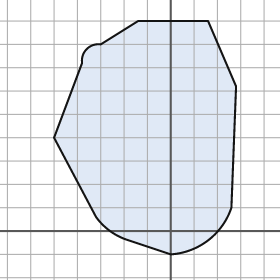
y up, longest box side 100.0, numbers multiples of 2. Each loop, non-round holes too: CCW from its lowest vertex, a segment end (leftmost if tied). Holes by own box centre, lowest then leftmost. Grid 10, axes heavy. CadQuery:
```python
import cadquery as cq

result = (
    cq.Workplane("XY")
    .moveTo(0.0, -10.0)
    .threePointArc((16.0, -4.0), (26.0, 10.0))
    .lineTo(28.0, 62.0)
    .lineTo(16.0, 90.0)
    .lineTo(-14.0, 90.0)
    .lineTo(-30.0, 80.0)
    .threePointArc((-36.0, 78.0), (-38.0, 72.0))
    .lineTo(-50.0, 40.0)
    .lineTo(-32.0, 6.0)
    .threePointArc((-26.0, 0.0), (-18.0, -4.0))
    .close()
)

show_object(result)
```